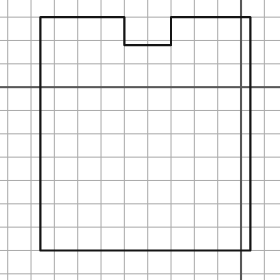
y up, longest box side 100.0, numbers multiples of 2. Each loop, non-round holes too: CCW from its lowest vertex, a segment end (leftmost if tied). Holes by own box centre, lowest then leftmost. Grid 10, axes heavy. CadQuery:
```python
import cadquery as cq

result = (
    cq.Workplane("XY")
    .moveTo(-86.0, -70.0)
    .lineTo(4.0, -70.0)
    .lineTo(4.0, 30.0)
    .lineTo(-30.0, 30.0)
    .lineTo(-30.0, 18.0)
    .lineTo(-50.0, 18.0)
    .lineTo(-50.0, 30.0)
    .lineTo(-86.0, 30.0)
    .close()
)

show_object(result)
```